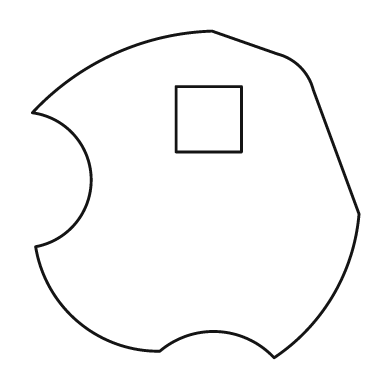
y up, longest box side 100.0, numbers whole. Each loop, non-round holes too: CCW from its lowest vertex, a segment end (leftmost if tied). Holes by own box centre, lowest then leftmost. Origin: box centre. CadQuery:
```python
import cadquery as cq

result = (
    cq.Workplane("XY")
    .moveTo(24.0, -50.0)
    .threePointArc((42.0, -31.0), (50.0, -6.0))
    .lineTo(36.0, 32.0)
    .threePointArc((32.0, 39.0), (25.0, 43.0))
    .lineTo(5.0, 50.0)
    .threePointArc((-25.0, 43.0), (-50.0, 25.0))
    .threePointArc((-32.0, 5.0), (-49.0, -16.0))
    .threePointArc((-36.0, -39.0), (-11.0, -48.0))
    .threePointArc((7.0, -42.0), (24.0, -50.0))
    .close()
    .moveTo(-6.0, 13.0)
    .lineTo(14.0, 13.0)
    .lineTo(14.0, 33.0)
    .lineTo(-6.0, 33.0)
    .close()
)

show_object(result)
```